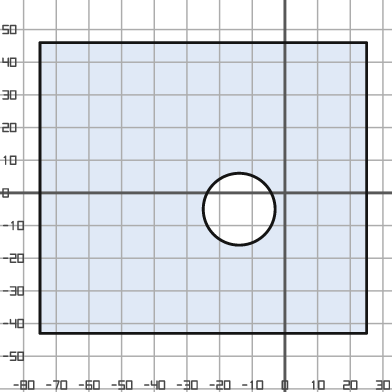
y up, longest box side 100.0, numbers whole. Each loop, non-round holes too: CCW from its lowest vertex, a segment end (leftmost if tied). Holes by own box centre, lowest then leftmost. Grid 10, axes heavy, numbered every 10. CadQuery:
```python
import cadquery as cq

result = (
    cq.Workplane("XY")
    .moveTo(-75.0, -43.0)
    .lineTo(25.0, -43.0)
    .lineTo(25.0, 46.0)
    .lineTo(-75.0, 46.0)
    .close()
    .moveTo(-14.0, -5.0)
    .circle(11.0)
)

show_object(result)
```